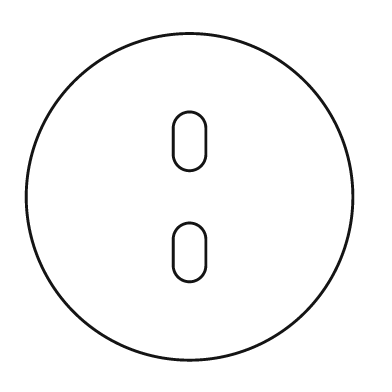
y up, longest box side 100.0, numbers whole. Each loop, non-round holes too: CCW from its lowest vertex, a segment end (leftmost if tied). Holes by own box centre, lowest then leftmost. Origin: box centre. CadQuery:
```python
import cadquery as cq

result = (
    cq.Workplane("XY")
    .moveTo(0.0, 0.0)
    .circle(50.0)
    .moveTo(-5.0, -21.0)
    .threePointArc((0.0, -26.0), (5.0, -21.0))
    .lineTo(5.0, -13.0)
    .threePointArc((0.0, -8.0), (-5.0, -13.0))
    .close()
    .moveTo(-5.0, 13.0)
    .threePointArc((0.0, 8.0), (5.0, 13.0))
    .lineTo(5.0, 21.0)
    .threePointArc((0.0, 26.0), (-5.0, 21.0))
    .close()
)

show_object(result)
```